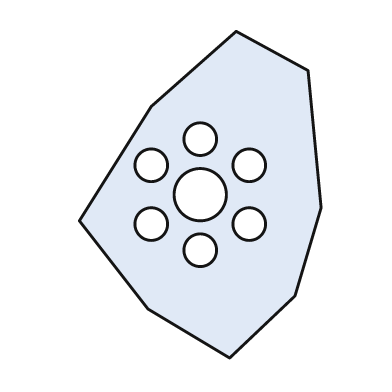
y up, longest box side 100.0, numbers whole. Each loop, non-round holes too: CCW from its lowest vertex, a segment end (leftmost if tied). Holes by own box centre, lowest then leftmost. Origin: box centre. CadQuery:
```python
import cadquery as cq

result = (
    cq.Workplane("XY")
    .moveTo(9.0, -50.0)
    .lineTo(29.0, -31.0)
    .lineTo(37.0, -4.0)
    .lineTo(33.0, 38.0)
    .lineTo(11.0, 50.0)
    .lineTo(-15.0, 27.0)
    .lineTo(-37.0, -8.0)
    .lineTo(-16.0, -35.0)
    .close()
    .moveTo(0.0, -17.0)
    .circle(5.0)
    .moveTo(-15.0, -9.0)
    .circle(5.0)
    .moveTo(15.0, -9.0)
    .circle(5.0)
    .moveTo(0.0, 0.0)
    .circle(8.0)
    .moveTo(-15.0, 9.0)
    .circle(5.0)
    .moveTo(15.0, 9.0)
    .circle(5.0)
    .moveTo(0.0, 17.0)
    .circle(5.0)
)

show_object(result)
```